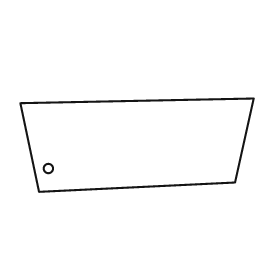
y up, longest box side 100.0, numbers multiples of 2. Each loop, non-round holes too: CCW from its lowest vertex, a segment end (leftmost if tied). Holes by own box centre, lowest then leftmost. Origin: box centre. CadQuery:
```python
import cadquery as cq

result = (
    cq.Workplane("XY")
    .moveTo(-42.0, -20.0)
    .lineTo(42.0, -16.0)
    .lineTo(50.0, 20.0)
    .lineTo(-50.0, 18.0)
    .close()
    .moveTo(-38.0, -10.0)
    .circle(2.0)
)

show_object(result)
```